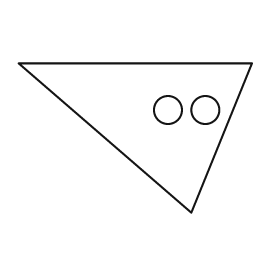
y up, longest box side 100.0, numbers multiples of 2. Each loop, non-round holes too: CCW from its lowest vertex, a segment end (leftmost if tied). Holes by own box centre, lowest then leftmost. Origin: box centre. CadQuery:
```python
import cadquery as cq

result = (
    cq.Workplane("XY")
    .moveTo(24.0, -32.0)
    .lineTo(50.0, 32.0)
    .lineTo(-50.0, 32.0)
    .close()
    .moveTo(14.0, 12.0)
    .circle(6.0)
    .moveTo(30.0, 12.0)
    .circle(6.0)
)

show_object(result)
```